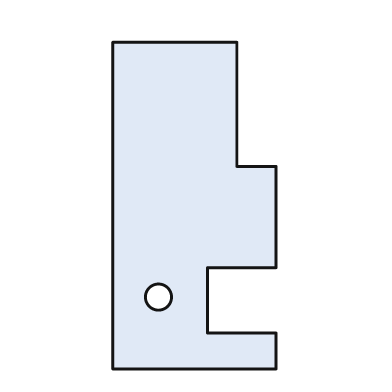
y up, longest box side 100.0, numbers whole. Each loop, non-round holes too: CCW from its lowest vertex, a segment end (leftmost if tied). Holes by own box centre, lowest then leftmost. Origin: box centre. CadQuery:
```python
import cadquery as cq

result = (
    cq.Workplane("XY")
    .moveTo(-25.0, -50.0)
    .lineTo(25.0, -50.0)
    .lineTo(25.0, -39.0)
    .lineTo(4.0, -39.0)
    .lineTo(4.0, -19.0)
    .lineTo(25.0, -19.0)
    .lineTo(25.0, 12.0)
    .lineTo(13.0, 12.0)
    .lineTo(13.0, 50.0)
    .lineTo(-25.0, 50.0)
    .close()
    .moveTo(-11.0, -28.0)
    .circle(4.0)
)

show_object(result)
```